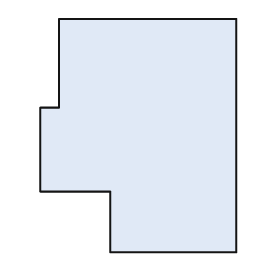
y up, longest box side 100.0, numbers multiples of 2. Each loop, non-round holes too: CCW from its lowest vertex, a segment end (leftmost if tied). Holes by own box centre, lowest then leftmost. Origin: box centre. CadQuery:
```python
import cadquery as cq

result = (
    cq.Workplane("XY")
    .moveTo(-12.0, -50.0)
    .lineTo(42.0, -50.0)
    .lineTo(42.0, 50.0)
    .lineTo(-34.0, 50.0)
    .lineTo(-34.0, 12.0)
    .lineTo(-42.0, 12.0)
    .lineTo(-42.0, -24.0)
    .lineTo(-12.0, -24.0)
    .close()
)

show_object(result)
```